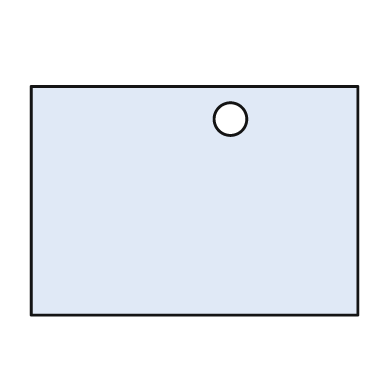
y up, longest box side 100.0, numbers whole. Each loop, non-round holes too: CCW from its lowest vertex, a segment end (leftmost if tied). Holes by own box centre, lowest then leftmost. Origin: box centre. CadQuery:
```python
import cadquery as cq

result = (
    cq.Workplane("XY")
    .moveTo(-50.0, -35.0)
    .lineTo(50.0, -35.0)
    .lineTo(50.0, 35.0)
    .lineTo(-50.0, 35.0)
    .close()
    .moveTo(11.0, 25.0)
    .circle(5.0)
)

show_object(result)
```